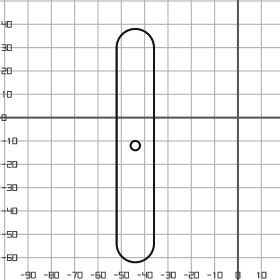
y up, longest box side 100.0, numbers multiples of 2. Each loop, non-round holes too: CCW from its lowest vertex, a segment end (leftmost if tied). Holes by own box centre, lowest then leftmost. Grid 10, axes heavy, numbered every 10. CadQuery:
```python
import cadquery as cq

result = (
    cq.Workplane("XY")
    .moveTo(-52.0, -54.0)
    .threePointArc((-44.0, -62.0), (-36.0, -54.0))
    .lineTo(-36.0, 30.0)
    .threePointArc((-44.0, 38.0), (-52.0, 30.0))
    .close()
    .moveTo(-44.0, -12.0)
    .circle(2.0)
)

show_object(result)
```